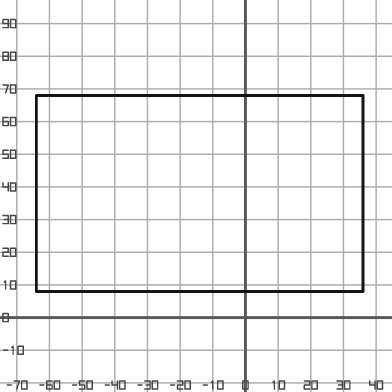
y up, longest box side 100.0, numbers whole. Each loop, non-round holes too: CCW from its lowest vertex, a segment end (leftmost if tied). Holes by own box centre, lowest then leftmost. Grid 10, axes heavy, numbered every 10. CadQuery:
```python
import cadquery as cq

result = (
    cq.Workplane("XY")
    .moveTo(-64.0, 8.0)
    .lineTo(36.0, 8.0)
    .lineTo(36.0, 68.0)
    .lineTo(-64.0, 68.0)
    .close()
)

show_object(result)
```